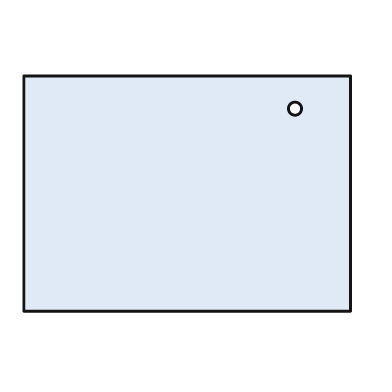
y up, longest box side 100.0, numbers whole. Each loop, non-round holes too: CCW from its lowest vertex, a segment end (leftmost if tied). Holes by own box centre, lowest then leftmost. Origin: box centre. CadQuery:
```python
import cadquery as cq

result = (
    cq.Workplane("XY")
    .moveTo(-50.0, -36.0)
    .lineTo(50.0, -36.0)
    .lineTo(50.0, 36.0)
    .lineTo(-50.0, 36.0)
    .close()
    .moveTo(33.0, 26.0)
    .circle(2.0)
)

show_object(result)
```